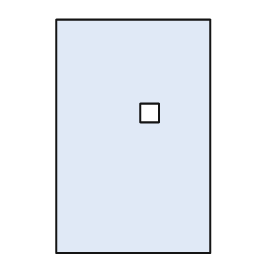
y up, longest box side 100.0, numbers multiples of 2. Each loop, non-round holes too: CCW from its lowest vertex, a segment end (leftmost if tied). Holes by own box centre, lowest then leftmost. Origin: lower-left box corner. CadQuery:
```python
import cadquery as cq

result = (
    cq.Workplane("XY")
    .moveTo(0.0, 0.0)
    .lineTo(66.0, 0.0)
    .lineTo(66.0, 100.0)
    .lineTo(0.0, 100.0)
    .close()
    .moveTo(36.0, 56.0)
    .lineTo(44.0, 56.0)
    .lineTo(44.0, 64.0)
    .lineTo(36.0, 64.0)
    .close()
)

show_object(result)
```